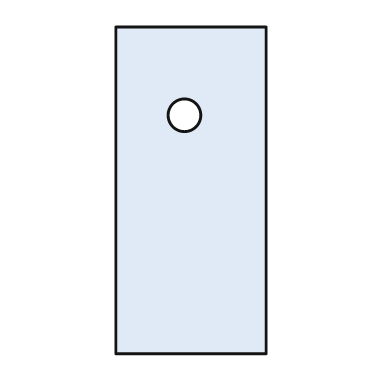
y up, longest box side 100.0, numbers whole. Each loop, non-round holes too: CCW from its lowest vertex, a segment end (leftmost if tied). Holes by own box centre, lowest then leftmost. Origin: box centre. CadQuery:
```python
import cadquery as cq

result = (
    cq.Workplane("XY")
    .moveTo(-23.0, -50.0)
    .lineTo(23.0, -50.0)
    .lineTo(23.0, 50.0)
    .lineTo(-23.0, 50.0)
    .close()
    .moveTo(-2.0, 23.0)
    .circle(5.0)
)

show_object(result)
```